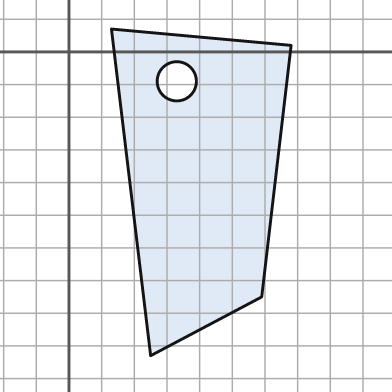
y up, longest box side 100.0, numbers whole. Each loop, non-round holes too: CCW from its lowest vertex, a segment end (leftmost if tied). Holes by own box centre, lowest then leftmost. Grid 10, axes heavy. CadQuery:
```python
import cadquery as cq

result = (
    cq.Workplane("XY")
    .moveTo(25.0, -93.0)
    .lineTo(59.0, -75.0)
    .lineTo(68.0, 2.0)
    .lineTo(13.0, 7.0)
    .close()
    .moveTo(33.0, -9.0)
    .circle(6.0)
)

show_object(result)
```